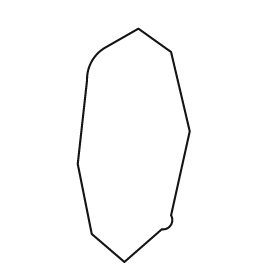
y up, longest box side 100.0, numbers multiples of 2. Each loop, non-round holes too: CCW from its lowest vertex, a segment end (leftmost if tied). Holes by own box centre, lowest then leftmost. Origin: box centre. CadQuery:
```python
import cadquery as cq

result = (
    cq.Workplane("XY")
    .moveTo(-4.0, -50.0)
    .lineTo(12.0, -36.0)
    .threePointArc((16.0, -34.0), (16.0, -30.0))
    .lineTo(24.0, 6.0)
    .lineTo(16.0, 40.0)
    .lineTo(2.0, 50.0)
    .lineTo(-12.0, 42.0)
    .threePointArc((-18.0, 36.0), (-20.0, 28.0))
    .lineTo(-24.0, -8.0)
    .lineTo(-18.0, -38.0)
    .close()
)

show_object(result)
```